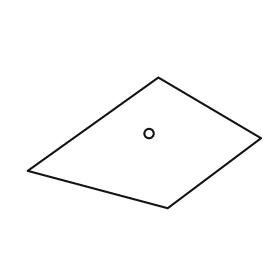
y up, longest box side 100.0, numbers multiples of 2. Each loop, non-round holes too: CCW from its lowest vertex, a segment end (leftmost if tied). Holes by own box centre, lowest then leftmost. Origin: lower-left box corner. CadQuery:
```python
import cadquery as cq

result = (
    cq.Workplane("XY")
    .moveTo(60.0, 0.0)
    .lineTo(100.0, 30.0)
    .lineTo(56.0, 56.0)
    .lineTo(0.0, 16.0)
    .close()
    .moveTo(52.0, 32.0)
    .circle(2.0)
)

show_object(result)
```